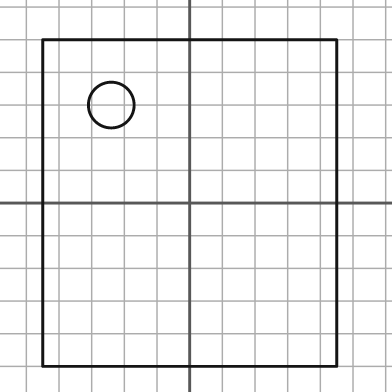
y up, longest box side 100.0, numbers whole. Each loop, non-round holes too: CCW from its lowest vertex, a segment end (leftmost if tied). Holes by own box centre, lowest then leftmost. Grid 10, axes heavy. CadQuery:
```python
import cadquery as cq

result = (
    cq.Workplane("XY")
    .moveTo(-45.0, -50.0)
    .lineTo(45.0, -50.0)
    .lineTo(45.0, 50.0)
    .lineTo(-45.0, 50.0)
    .close()
    .moveTo(-24.0, 30.0)
    .circle(7.0)
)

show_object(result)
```